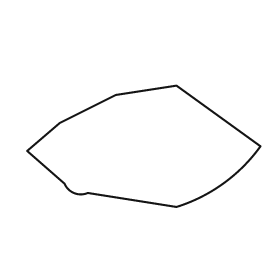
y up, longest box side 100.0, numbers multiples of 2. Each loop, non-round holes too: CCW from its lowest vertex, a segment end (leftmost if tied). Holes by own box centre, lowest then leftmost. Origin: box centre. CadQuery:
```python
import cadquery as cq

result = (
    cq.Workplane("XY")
    .moveTo(14.0, -26.0)
    .threePointArc((34.0, -16.0), (50.0, 0.0))
    .lineTo(14.0, 26.0)
    .lineTo(-12.0, 22.0)
    .lineTo(-36.0, 10.0)
    .lineTo(-50.0, -2.0)
    .lineTo(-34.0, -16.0)
    .threePointArc((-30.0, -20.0), (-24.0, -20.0))
    .close()
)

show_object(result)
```